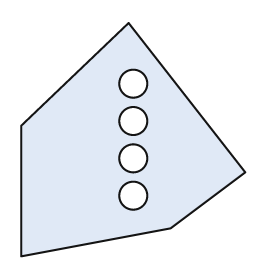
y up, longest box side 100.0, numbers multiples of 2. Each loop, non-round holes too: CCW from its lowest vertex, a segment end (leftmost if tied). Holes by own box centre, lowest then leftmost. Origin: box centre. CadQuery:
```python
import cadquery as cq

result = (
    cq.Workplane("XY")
    .moveTo(-48.0, -50.0)
    .lineTo(16.0, -38.0)
    .lineTo(48.0, -14.0)
    .lineTo(-2.0, 50.0)
    .lineTo(-48.0, 6.0)
    .close()
    .moveTo(0.0, -24.0)
    .circle(6.0)
    .moveTo(0.0, -8.0)
    .circle(6.0)
    .moveTo(0.0, 8.0)
    .circle(6.0)
    .moveTo(0.0, 24.0)
    .circle(6.0)
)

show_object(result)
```